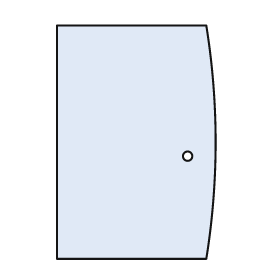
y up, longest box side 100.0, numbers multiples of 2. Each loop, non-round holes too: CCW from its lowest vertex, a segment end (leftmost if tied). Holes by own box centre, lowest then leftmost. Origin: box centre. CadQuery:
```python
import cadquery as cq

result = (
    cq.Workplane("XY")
    .moveTo(-34.0, -50.0)
    .lineTo(30.0, -50.0)
    .threePointArc((34.0, 0.0), (30.0, 50.0))
    .lineTo(-34.0, 50.0)
    .close()
    .moveTo(22.0, -6.0)
    .circle(2.0)
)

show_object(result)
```